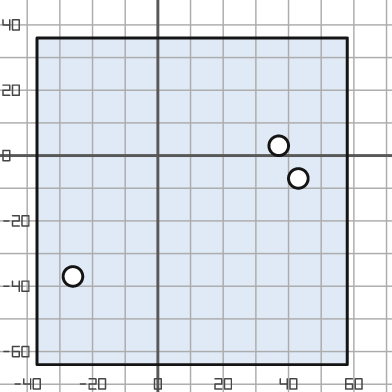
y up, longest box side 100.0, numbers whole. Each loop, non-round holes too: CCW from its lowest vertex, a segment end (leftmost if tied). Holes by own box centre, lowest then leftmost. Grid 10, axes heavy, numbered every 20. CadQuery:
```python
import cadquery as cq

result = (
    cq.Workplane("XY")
    .moveTo(-37.0, -64.0)
    .lineTo(58.0, -64.0)
    .lineTo(58.0, 36.0)
    .lineTo(-37.0, 36.0)
    .close()
    .moveTo(-26.0, -37.0)
    .circle(3.0)
    .moveTo(43.0, -7.0)
    .circle(3.0)
    .moveTo(37.0, 3.0)
    .circle(3.0)
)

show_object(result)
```